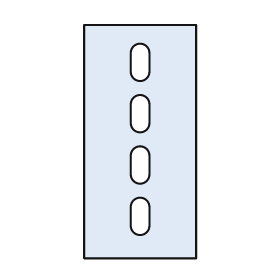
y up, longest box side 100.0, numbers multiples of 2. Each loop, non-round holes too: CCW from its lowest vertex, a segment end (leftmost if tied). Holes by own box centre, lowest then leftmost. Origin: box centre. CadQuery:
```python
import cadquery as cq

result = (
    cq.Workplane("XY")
    .moveTo(-24.0, -50.0)
    .lineTo(24.0, -50.0)
    .lineTo(24.0, 50.0)
    .lineTo(-24.0, 50.0)
    .close()
    .moveTo(-4.0, -36.0)
    .threePointArc((0.0, -40.0), (4.0, -36.0))
    .lineTo(4.0, -28.0)
    .threePointArc((0.0, -24.0), (-4.0, -28.0))
    .close()
    .moveTo(-4.0, -14.0)
    .threePointArc((0.0, -18.0), (4.0, -14.0))
    .lineTo(4.0, -6.0)
    .threePointArc((0.0, -2.0), (-4.0, -6.0))
    .close()
    .moveTo(-4.0, 8.0)
    .threePointArc((0.0, 4.0), (4.0, 8.0))
    .lineTo(4.0, 16.0)
    .threePointArc((0.0, 20.0), (-4.0, 16.0))
    .close()
    .moveTo(-4.0, 30.0)
    .threePointArc((0.0, 26.0), (4.0, 30.0))
    .lineTo(4.0, 38.0)
    .threePointArc((0.0, 42.0), (-4.0, 38.0))
    .close()
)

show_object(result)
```